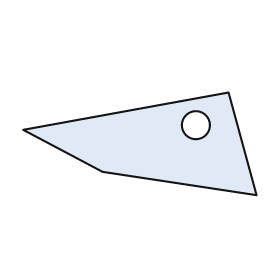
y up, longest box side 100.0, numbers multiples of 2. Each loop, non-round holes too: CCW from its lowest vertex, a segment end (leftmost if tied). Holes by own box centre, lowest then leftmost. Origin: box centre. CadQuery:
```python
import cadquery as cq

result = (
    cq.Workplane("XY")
    .moveTo(50.0, -22.0)
    .lineTo(38.0, 22.0)
    .lineTo(-50.0, 6.0)
    .lineTo(-16.0, -12.0)
    .close()
    .moveTo(24.0, 8.0)
    .circle(6.0)
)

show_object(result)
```